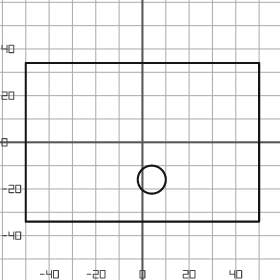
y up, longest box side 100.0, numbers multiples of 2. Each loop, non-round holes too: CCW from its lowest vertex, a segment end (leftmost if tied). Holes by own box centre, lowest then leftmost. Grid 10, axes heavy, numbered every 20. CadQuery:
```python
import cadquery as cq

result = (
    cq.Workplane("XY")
    .moveTo(-50.0, -34.0)
    .lineTo(50.0, -34.0)
    .lineTo(50.0, 34.0)
    .lineTo(-50.0, 34.0)
    .close()
    .moveTo(4.0, -16.0)
    .circle(6.0)
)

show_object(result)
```